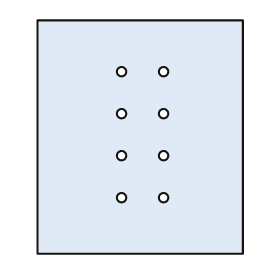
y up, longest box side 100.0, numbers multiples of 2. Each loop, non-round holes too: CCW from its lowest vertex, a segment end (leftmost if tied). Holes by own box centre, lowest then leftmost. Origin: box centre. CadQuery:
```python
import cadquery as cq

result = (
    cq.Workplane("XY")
    .moveTo(-44.0, -50.0)
    .lineTo(44.0, -50.0)
    .lineTo(44.0, 50.0)
    .lineTo(-44.0, 50.0)
    .close()
    .moveTo(-8.0, -26.0)
    .circle(2.0)
    .moveTo(10.0, -26.0)
    .circle(2.0)
    .moveTo(-8.0, -8.0)
    .circle(2.0)
    .moveTo(10.0, -8.0)
    .circle(2.0)
    .moveTo(-8.0, 10.0)
    .circle(2.0)
    .moveTo(10.0, 10.0)
    .circle(2.0)
    .moveTo(-8.0, 28.0)
    .circle(2.0)
    .moveTo(10.0, 28.0)
    .circle(2.0)
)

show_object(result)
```